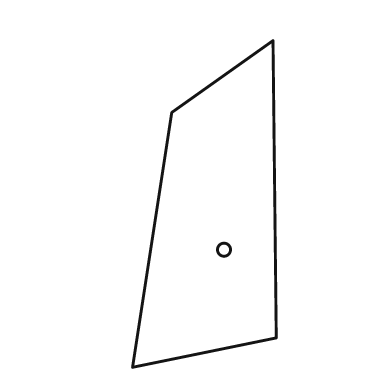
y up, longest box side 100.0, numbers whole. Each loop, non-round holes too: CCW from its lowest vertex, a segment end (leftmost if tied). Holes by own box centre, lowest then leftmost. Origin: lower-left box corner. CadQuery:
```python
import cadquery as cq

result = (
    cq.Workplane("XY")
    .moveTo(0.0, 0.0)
    .lineTo(44.0, 9.0)
    .lineTo(43.0, 100.0)
    .lineTo(12.0, 78.0)
    .close()
    .moveTo(28.0, 36.0)
    .circle(2.0)
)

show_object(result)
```